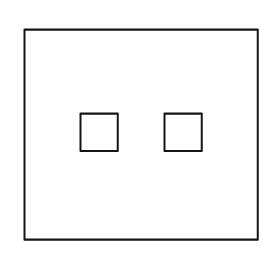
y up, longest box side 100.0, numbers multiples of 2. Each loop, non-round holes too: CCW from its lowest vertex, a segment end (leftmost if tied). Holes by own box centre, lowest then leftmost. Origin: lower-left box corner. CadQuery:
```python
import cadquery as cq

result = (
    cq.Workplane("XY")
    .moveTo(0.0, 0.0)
    .lineTo(100.0, 0.0)
    .lineTo(100.0, 90.0)
    .lineTo(0.0, 90.0)
    .close()
    .moveTo(24.0, 38.0)
    .lineTo(40.0, 38.0)
    .lineTo(40.0, 54.0)
    .lineTo(24.0, 54.0)
    .close()
    .moveTo(60.0, 38.0)
    .lineTo(76.0, 38.0)
    .lineTo(76.0, 54.0)
    .lineTo(60.0, 54.0)
    .close()
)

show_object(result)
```